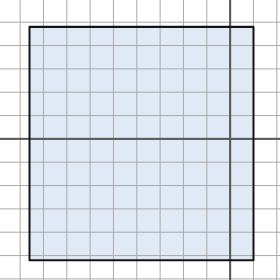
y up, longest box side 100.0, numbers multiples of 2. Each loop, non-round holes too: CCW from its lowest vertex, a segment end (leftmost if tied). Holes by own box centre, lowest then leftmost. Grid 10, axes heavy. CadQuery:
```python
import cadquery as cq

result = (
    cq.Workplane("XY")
    .moveTo(-86.0, -52.0)
    .lineTo(10.0, -52.0)
    .lineTo(10.0, 48.0)
    .lineTo(-86.0, 48.0)
    .close()
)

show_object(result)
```